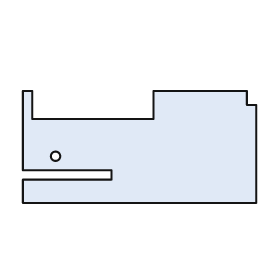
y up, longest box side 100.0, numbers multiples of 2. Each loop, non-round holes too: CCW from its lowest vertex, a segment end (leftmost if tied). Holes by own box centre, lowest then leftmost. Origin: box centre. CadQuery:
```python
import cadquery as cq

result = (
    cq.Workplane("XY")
    .moveTo(-50.0, -24.0)
    .lineTo(50.0, -24.0)
    .lineTo(50.0, 18.0)
    .lineTo(46.0, 18.0)
    .lineTo(46.0, 24.0)
    .lineTo(6.0, 24.0)
    .lineTo(6.0, 12.0)
    .lineTo(-46.0, 12.0)
    .lineTo(-46.0, 24.0)
    .lineTo(-50.0, 24.0)
    .lineTo(-50.0, -10.0)
    .lineTo(-12.0, -10.0)
    .lineTo(-12.0, -14.0)
    .lineTo(-50.0, -14.0)
    .close()
    .moveTo(-36.0, -4.0)
    .circle(2.0)
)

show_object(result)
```